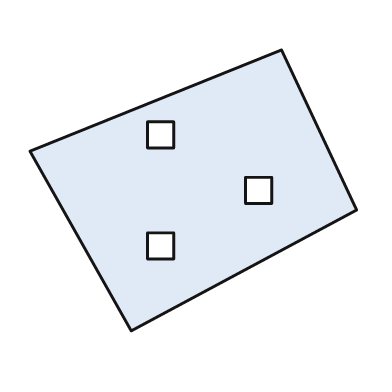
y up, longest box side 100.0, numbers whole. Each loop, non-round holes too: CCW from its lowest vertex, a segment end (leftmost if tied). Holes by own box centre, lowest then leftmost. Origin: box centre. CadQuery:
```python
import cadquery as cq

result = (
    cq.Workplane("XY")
    .moveTo(-19.0, -43.0)
    .lineTo(50.0, -6.0)
    .lineTo(27.0, 43.0)
    .lineTo(-50.0, 12.0)
    .close()
    .moveTo(-14.0, -21.0)
    .lineTo(-6.0, -21.0)
    .lineTo(-6.0, -13.0)
    .lineTo(-14.0, -13.0)
    .close()
    .moveTo(16.0, -4.0)
    .lineTo(24.0, -4.0)
    .lineTo(24.0, 4.0)
    .lineTo(16.0, 4.0)
    .close()
    .moveTo(-14.0, 13.0)
    .lineTo(-6.0, 13.0)
    .lineTo(-6.0, 21.0)
    .lineTo(-14.0, 21.0)
    .close()
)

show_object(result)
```